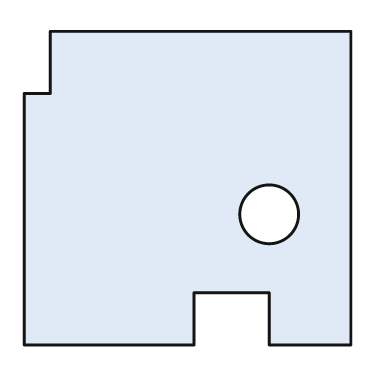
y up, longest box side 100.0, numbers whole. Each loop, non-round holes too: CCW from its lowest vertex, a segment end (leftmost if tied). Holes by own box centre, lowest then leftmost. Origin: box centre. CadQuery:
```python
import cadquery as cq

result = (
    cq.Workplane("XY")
    .moveTo(-50.0, -48.0)
    .lineTo(2.0, -48.0)
    .lineTo(2.0, -32.0)
    .lineTo(25.0, -32.0)
    .lineTo(25.0, -48.0)
    .lineTo(50.0, -48.0)
    .lineTo(50.0, 48.0)
    .lineTo(-42.0, 48.0)
    .lineTo(-42.0, 29.0)
    .lineTo(-50.0, 29.0)
    .close()
    .moveTo(25.0, -8.0)
    .circle(9.0)
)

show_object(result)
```